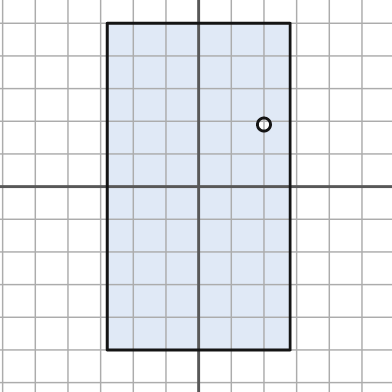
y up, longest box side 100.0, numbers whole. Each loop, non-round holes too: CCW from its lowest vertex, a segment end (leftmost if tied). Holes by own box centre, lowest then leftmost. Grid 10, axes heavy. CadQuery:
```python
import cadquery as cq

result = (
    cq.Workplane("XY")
    .moveTo(-28.0, -50.0)
    .lineTo(28.0, -50.0)
    .lineTo(28.0, 50.0)
    .lineTo(-28.0, 50.0)
    .close()
    .moveTo(20.0, 19.0)
    .circle(2.0)
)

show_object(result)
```